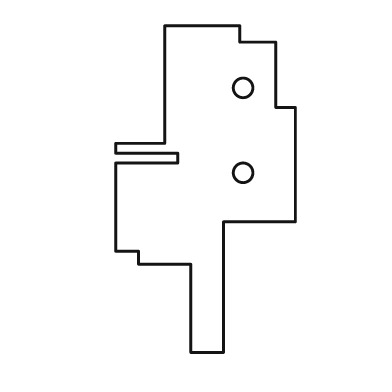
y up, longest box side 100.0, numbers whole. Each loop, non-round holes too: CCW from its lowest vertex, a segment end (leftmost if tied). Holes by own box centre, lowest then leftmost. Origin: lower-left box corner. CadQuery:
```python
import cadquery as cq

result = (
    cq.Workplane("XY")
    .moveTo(23.0, 0.0)
    .lineTo(33.0, 0.0)
    .lineTo(33.0, 40.0)
    .lineTo(55.0, 40.0)
    .lineTo(55.0, 75.0)
    .lineTo(49.0, 75.0)
    .lineTo(49.0, 95.0)
    .lineTo(38.0, 95.0)
    .lineTo(38.0, 100.0)
    .lineTo(15.0, 100.0)
    .lineTo(15.0, 64.0)
    .lineTo(0.0, 64.0)
    .lineTo(0.0, 61.0)
    .lineTo(19.0, 61.0)
    .lineTo(19.0, 58.0)
    .lineTo(0.0, 58.0)
    .lineTo(0.0, 31.0)
    .lineTo(7.0, 31.0)
    .lineTo(7.0, 27.0)
    .lineTo(23.0, 27.0)
    .close()
    .moveTo(39.0, 55.0)
    .circle(3.0)
    .moveTo(39.0, 81.0)
    .circle(3.0)
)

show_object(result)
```